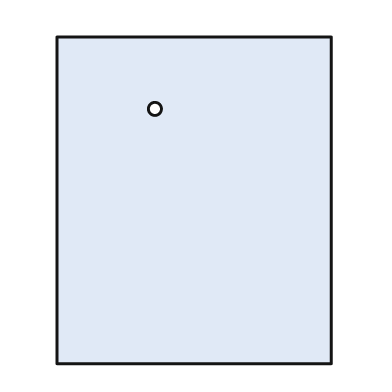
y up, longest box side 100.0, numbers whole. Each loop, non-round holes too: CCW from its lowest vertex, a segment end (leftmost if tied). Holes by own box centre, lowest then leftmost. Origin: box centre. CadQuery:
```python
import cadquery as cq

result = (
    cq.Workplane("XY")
    .moveTo(-42.0, -50.0)
    .lineTo(42.0, -50.0)
    .lineTo(42.0, 50.0)
    .lineTo(-42.0, 50.0)
    .close()
    .moveTo(-12.0, 28.0)
    .circle(2.0)
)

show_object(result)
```